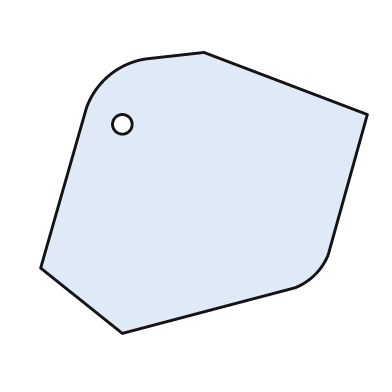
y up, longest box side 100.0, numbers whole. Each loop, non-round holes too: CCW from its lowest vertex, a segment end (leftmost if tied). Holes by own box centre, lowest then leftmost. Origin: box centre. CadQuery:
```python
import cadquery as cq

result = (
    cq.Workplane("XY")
    .moveTo(-25.0, -43.0)
    .lineTo(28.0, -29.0)
    .threePointArc((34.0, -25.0), (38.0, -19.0))
    .lineTo(50.0, 24.0)
    .lineTo(0.0, 43.0)
    .lineTo(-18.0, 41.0)
    .threePointArc((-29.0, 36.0), (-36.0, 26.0))
    .lineTo(-50.0, -23.0)
    .close()
    .moveTo(-25.0, 21.0)
    .circle(3.0)
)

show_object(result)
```